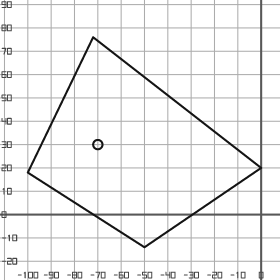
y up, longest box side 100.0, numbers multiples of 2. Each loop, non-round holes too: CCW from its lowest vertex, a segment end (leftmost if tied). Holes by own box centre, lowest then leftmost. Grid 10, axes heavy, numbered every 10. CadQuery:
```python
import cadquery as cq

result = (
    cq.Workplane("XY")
    .moveTo(-50.0, -14.0)
    .lineTo(0.0, 20.0)
    .lineTo(-72.0, 76.0)
    .lineTo(-100.0, 18.0)
    .close()
    .moveTo(-70.0, 30.0)
    .circle(2.0)
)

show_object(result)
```